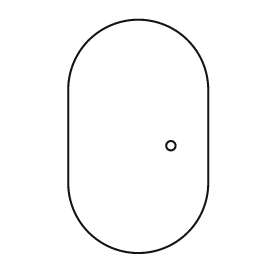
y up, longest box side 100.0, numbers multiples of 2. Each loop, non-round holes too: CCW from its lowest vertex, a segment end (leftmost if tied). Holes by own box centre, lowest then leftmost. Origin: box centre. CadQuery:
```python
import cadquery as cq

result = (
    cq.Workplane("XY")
    .moveTo(-30.0, -20.0)
    .threePointArc((0.0, -50.0), (30.0, -20.0))
    .lineTo(30.0, 20.0)
    .threePointArc((0.0, 50.0), (-30.0, 20.0))
    .close()
    .moveTo(14.0, -4.0)
    .circle(2.0)
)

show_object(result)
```